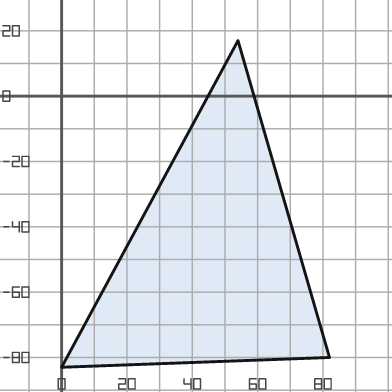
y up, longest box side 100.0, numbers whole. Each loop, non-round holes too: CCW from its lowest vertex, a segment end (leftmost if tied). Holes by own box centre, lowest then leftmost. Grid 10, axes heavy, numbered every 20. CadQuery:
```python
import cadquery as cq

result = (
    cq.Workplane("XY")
    .moveTo(0.0, -83.0)
    .lineTo(82.0, -80.0)
    .lineTo(54.0, 17.0)
    .close()
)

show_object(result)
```